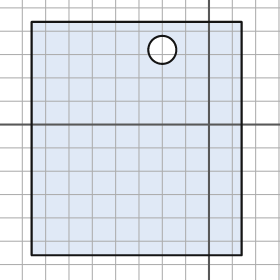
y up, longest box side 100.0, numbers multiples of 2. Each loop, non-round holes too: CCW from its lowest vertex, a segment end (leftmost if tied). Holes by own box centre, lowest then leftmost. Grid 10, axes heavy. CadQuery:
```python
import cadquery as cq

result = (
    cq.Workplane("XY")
    .moveTo(-76.0, -56.0)
    .lineTo(14.0, -56.0)
    .lineTo(14.0, 44.0)
    .lineTo(-76.0, 44.0)
    .close()
    .moveTo(-20.0, 32.0)
    .circle(6.0)
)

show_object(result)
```